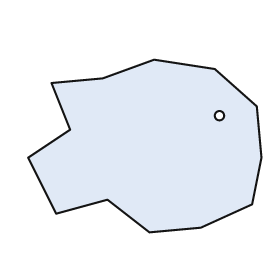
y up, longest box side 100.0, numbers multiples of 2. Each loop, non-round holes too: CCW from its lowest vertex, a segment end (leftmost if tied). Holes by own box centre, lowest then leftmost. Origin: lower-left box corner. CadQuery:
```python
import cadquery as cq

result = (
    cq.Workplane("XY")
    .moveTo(52.0, 0.0)
    .lineTo(74.0, 2.0)
    .lineTo(96.0, 12.0)
    .lineTo(100.0, 32.0)
    .lineTo(98.0, 54.0)
    .lineTo(80.0, 70.0)
    .lineTo(54.0, 74.0)
    .lineTo(32.0, 66.0)
    .lineTo(10.0, 64.0)
    .lineTo(18.0, 44.0)
    .lineTo(0.0, 32.0)
    .lineTo(12.0, 8.0)
    .lineTo(34.0, 14.0)
    .close()
    .moveTo(82.0, 50.0)
    .circle(2.0)
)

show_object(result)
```